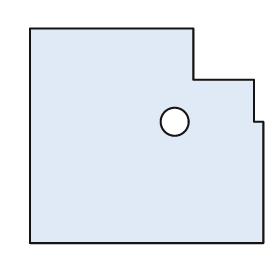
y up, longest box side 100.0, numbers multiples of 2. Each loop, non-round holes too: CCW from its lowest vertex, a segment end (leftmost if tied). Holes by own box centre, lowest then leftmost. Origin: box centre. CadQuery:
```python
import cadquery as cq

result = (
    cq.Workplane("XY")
    .moveTo(-50.0, -46.0)
    .lineTo(50.0, -46.0)
    .lineTo(50.0, 6.0)
    .lineTo(46.0, 6.0)
    .lineTo(46.0, 24.0)
    .lineTo(20.0, 24.0)
    .lineTo(20.0, 46.0)
    .lineTo(-50.0, 46.0)
    .close()
    .moveTo(12.0, 6.0)
    .circle(6.0)
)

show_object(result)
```